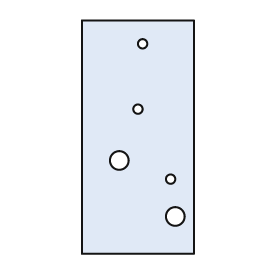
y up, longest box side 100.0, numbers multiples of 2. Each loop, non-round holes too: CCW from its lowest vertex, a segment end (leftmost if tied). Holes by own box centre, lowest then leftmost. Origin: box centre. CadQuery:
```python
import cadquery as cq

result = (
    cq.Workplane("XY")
    .moveTo(-24.0, -50.0)
    .lineTo(24.0, -50.0)
    .lineTo(24.0, 50.0)
    .lineTo(-24.0, 50.0)
    .close()
    .moveTo(16.0, -34.0)
    .circle(4.0)
    .moveTo(14.0, -18.0)
    .circle(2.0)
    .moveTo(-8.0, -10.0)
    .circle(4.0)
    .moveTo(0.0, 12.0)
    .circle(2.0)
    .moveTo(2.0, 40.0)
    .circle(2.0)
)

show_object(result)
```